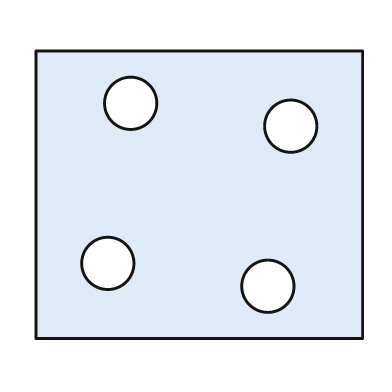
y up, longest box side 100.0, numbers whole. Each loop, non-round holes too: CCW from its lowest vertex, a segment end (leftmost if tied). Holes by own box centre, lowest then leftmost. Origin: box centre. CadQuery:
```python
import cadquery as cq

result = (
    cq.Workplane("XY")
    .moveTo(-50.0, -44.0)
    .lineTo(50.0, -44.0)
    .lineTo(50.0, 44.0)
    .lineTo(-50.0, 44.0)
    .close()
    .moveTo(21.0, -28.0)
    .circle(8.0)
    .moveTo(-28.0, -21.0)
    .circle(8.0)
    .moveTo(28.0, 21.0)
    .circle(8.0)
    .moveTo(-21.0, 28.0)
    .circle(8.0)
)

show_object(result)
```